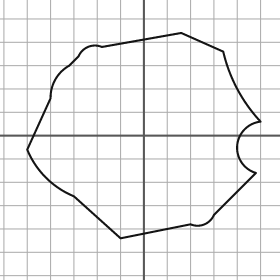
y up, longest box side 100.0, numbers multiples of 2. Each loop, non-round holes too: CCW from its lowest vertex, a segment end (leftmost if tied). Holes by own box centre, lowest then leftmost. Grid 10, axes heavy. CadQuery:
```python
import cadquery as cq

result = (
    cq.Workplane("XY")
    .moveTo(-10.0, -44.0)
    .lineTo(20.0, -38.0)
    .threePointArc((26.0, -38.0), (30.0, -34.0))
    .lineTo(48.0, -16.0)
    .threePointArc((40.0, -4.0), (50.0, 6.0))
    .threePointArc((40.0, 20.0), (34.0, 36.0))
    .lineTo(16.0, 44.0)
    .lineTo(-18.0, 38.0)
    .threePointArc((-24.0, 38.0), (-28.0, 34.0))
    .lineTo(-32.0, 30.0)
    .threePointArc((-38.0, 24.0), (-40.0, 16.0))
    .lineTo(-50.0, -6.0)
    .threePointArc((-42.0, -18.0), (-30.0, -26.0))
    .close()
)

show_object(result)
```